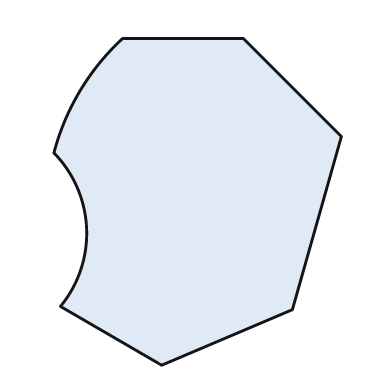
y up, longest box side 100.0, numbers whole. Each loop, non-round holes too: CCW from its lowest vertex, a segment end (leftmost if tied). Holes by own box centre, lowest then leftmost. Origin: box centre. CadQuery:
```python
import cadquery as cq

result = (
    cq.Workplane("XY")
    .moveTo(-11.0, -50.0)
    .lineTo(29.0, -33.0)
    .lineTo(44.0, 20.0)
    .lineTo(14.0, 50.0)
    .lineTo(-23.0, 50.0)
    .threePointArc((-36.0, 34.0), (-44.0, 15.0))
    .threePointArc((-34.0, -8.0), (-42.0, -32.0))
    .close()
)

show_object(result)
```